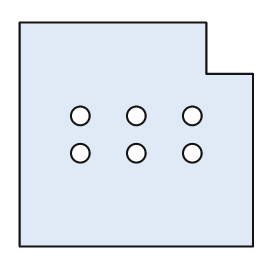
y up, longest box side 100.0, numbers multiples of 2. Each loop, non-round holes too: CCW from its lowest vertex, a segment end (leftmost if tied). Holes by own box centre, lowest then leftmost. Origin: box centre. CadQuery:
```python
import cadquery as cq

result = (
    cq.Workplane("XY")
    .moveTo(-50.0, -48.0)
    .lineTo(50.0, -48.0)
    .lineTo(50.0, 26.0)
    .lineTo(30.0, 26.0)
    .lineTo(30.0, 48.0)
    .lineTo(-50.0, 48.0)
    .close()
    .moveTo(-24.0, -8.0)
    .circle(4.0)
    .moveTo(0.0, -8.0)
    .circle(4.0)
    .moveTo(24.0, -8.0)
    .circle(4.0)
    .moveTo(-24.0, 8.0)
    .circle(4.0)
    .moveTo(0.0, 8.0)
    .circle(4.0)
    .moveTo(24.0, 8.0)
    .circle(4.0)
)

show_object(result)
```